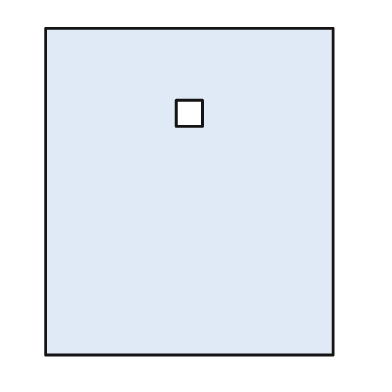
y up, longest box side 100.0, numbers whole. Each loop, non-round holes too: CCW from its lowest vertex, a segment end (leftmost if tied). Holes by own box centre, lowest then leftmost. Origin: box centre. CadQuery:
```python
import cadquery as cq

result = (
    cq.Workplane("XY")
    .moveTo(-44.0, -50.0)
    .lineTo(44.0, -50.0)
    .lineTo(44.0, 50.0)
    .lineTo(-44.0, 50.0)
    .close()
    .moveTo(-4.0, 20.0)
    .lineTo(4.0, 20.0)
    .lineTo(4.0, 28.0)
    .lineTo(-4.0, 28.0)
    .close()
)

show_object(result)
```